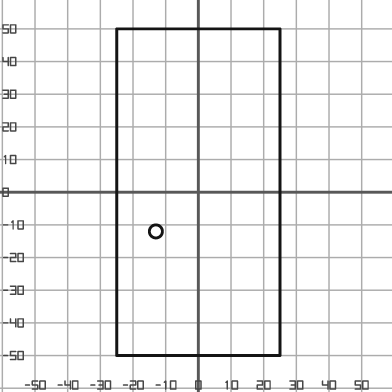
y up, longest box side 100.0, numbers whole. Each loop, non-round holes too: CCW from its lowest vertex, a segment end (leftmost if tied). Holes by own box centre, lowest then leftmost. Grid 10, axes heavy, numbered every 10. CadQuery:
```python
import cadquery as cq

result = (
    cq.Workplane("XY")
    .moveTo(-25.0, -50.0)
    .lineTo(25.0, -50.0)
    .lineTo(25.0, 50.0)
    .lineTo(-25.0, 50.0)
    .close()
    .moveTo(-13.0, -12.0)
    .circle(2.0)
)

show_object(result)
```